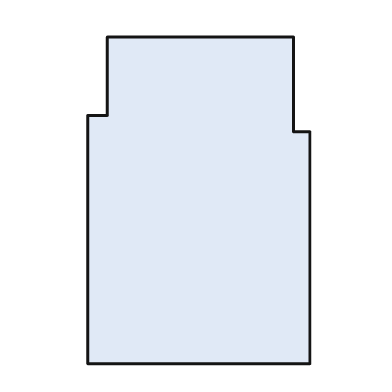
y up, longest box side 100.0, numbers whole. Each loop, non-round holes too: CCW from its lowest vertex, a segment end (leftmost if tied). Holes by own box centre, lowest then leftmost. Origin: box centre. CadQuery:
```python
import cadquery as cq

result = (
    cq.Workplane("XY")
    .moveTo(-34.0, -50.0)
    .lineTo(34.0, -50.0)
    .lineTo(34.0, 21.0)
    .lineTo(29.0, 21.0)
    .lineTo(29.0, 50.0)
    .lineTo(-28.0, 50.0)
    .lineTo(-28.0, 26.0)
    .lineTo(-34.0, 26.0)
    .close()
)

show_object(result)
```